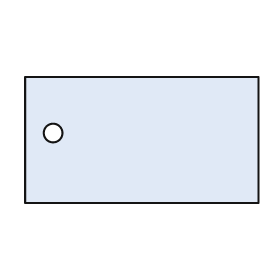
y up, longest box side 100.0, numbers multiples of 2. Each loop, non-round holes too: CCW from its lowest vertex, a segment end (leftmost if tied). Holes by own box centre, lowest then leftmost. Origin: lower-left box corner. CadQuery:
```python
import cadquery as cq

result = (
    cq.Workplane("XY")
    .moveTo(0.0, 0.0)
    .lineTo(100.0, 0.0)
    .lineTo(100.0, 54.0)
    .lineTo(0.0, 54.0)
    .close()
    .moveTo(12.0, 30.0)
    .circle(4.0)
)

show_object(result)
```